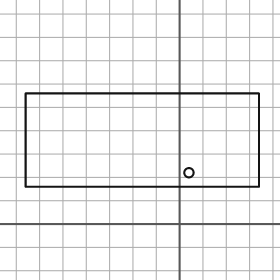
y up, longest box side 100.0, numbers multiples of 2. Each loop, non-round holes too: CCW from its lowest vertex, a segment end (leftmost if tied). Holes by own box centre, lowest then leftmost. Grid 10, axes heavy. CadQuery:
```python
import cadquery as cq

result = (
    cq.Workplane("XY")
    .moveTo(-66.0, 16.0)
    .lineTo(34.0, 16.0)
    .lineTo(34.0, 56.0)
    .lineTo(-66.0, 56.0)
    .close()
    .moveTo(4.0, 22.0)
    .circle(2.0)
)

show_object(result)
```